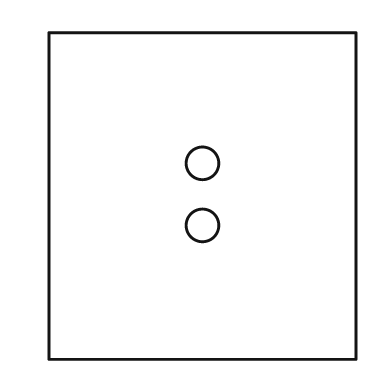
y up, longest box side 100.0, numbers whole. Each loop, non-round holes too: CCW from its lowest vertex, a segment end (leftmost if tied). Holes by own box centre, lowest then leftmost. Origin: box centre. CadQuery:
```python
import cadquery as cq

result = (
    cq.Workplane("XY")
    .moveTo(-47.0, -50.0)
    .lineTo(47.0, -50.0)
    .lineTo(47.0, 50.0)
    .lineTo(-47.0, 50.0)
    .close()
    .moveTo(0.0, -9.0)
    .circle(5.0)
    .moveTo(0.0, 10.0)
    .circle(5.0)
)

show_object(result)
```